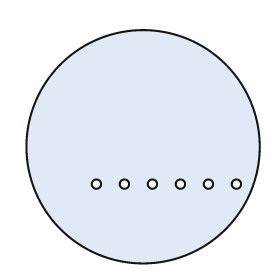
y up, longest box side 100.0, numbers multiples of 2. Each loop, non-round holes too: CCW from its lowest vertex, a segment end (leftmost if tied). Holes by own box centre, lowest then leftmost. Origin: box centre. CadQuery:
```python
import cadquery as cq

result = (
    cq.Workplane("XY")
    .moveTo(0.0, 0.0)
    .circle(50.0)
    .moveTo(-20.0, -16.0)
    .circle(2.0)
    .moveTo(-8.0, -16.0)
    .circle(2.0)
    .moveTo(4.0, -16.0)
    .circle(2.0)
    .moveTo(16.0, -16.0)
    .circle(2.0)
    .moveTo(28.0, -16.0)
    .circle(2.0)
    .moveTo(40.0, -16.0)
    .circle(2.0)
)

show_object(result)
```